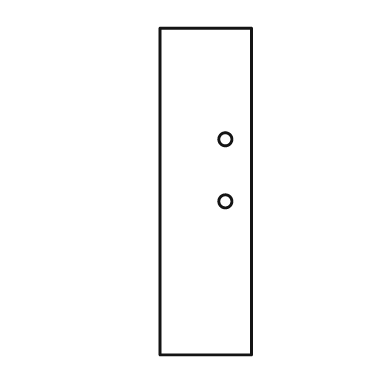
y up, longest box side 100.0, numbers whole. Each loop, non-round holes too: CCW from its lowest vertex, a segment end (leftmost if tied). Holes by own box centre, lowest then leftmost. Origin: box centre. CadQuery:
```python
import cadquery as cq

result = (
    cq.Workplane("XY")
    .moveTo(-14.0, -50.0)
    .lineTo(14.0, -50.0)
    .lineTo(14.0, 50.0)
    .lineTo(-14.0, 50.0)
    .close()
    .moveTo(6.0, -3.0)
    .circle(2.0)
    .moveTo(6.0, 16.0)
    .circle(2.0)
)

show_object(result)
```